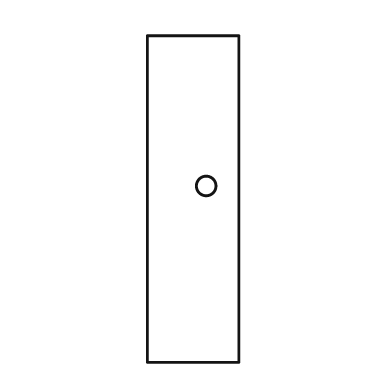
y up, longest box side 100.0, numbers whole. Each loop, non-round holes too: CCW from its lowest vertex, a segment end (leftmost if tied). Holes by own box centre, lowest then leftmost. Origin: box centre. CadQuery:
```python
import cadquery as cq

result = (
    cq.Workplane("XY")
    .moveTo(-14.0, -50.0)
    .lineTo(14.0, -50.0)
    .lineTo(14.0, 50.0)
    .lineTo(-14.0, 50.0)
    .close()
    .moveTo(4.0, 4.0)
    .circle(3.0)
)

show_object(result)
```